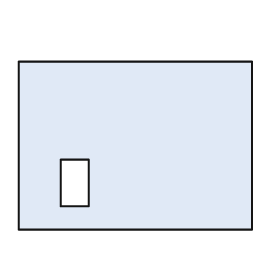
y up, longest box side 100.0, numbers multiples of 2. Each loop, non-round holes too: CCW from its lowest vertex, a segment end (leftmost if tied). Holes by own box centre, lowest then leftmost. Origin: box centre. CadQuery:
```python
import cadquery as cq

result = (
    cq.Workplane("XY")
    .moveTo(-50.0, -36.0)
    .lineTo(50.0, -36.0)
    .lineTo(50.0, 36.0)
    .lineTo(-50.0, 36.0)
    .close()
    .moveTo(-32.0, -26.0)
    .lineTo(-20.0, -26.0)
    .lineTo(-20.0, -6.0)
    .lineTo(-32.0, -6.0)
    .close()
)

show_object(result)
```